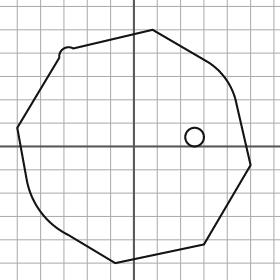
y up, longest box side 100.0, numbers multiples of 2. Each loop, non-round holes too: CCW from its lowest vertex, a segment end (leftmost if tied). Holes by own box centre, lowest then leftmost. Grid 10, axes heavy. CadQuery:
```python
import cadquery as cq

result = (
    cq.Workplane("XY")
    .moveTo(-8.0, -50.0)
    .lineTo(30.0, -42.0)
    .lineTo(50.0, -8.0)
    .lineTo(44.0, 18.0)
    .threePointArc((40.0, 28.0), (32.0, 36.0))
    .lineTo(8.0, 50.0)
    .lineTo(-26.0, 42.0)
    .threePointArc((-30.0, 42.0), (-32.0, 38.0))
    .lineTo(-50.0, 8.0)
    .lineTo(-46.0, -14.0)
    .threePointArc((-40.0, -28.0), (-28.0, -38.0))
    .close()
    .moveTo(26.0, 4.0)
    .circle(4.0)
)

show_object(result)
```